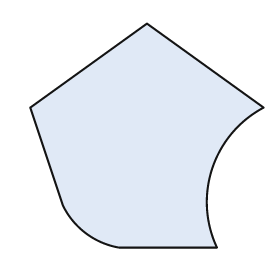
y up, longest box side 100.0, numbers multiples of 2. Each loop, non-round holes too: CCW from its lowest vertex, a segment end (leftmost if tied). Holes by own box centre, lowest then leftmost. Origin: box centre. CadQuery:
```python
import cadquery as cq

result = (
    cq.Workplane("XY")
    .moveTo(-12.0, -48.0)
    .lineTo(30.0, -48.0)
    .threePointArc((28.0, -14.0), (50.0, 12.0))
    .lineTo(0.0, 48.0)
    .lineTo(-50.0, 12.0)
    .lineTo(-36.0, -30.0)
    .threePointArc((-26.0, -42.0), (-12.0, -48.0))
    .close()
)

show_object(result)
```